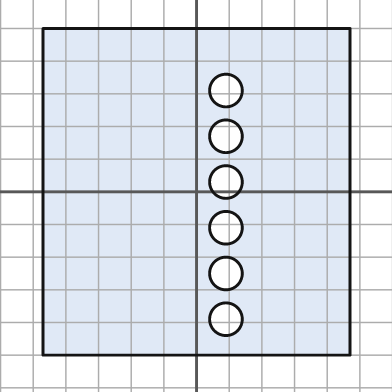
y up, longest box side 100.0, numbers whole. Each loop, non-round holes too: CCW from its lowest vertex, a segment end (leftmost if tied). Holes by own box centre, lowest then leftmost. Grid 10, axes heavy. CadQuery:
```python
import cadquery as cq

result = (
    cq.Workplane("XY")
    .moveTo(-47.0, -50.0)
    .lineTo(47.0, -50.0)
    .lineTo(47.0, 50.0)
    .lineTo(-47.0, 50.0)
    .close()
    .moveTo(9.0, -39.0)
    .circle(5.0)
    .moveTo(9.0, -25.0)
    .circle(5.0)
    .moveTo(9.0, -11.0)
    .circle(5.0)
    .moveTo(9.0, 3.0)
    .circle(5.0)
    .moveTo(9.0, 17.0)
    .circle(5.0)
    .moveTo(9.0, 31.0)
    .circle(5.0)
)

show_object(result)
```